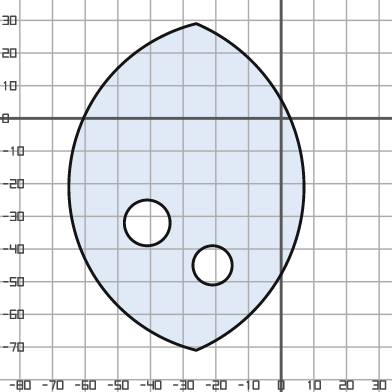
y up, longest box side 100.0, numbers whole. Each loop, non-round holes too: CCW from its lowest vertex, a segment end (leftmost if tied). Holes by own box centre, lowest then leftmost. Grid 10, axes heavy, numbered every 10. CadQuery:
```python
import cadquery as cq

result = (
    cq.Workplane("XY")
    .moveTo(-26.0, -71.0)
    .threePointArc((7.0, -21.0), (-26.0, 29.0))
    .threePointArc((-65.0, -21.0), (-26.0, -71.0))
    .close()
    .moveTo(-21.0, -45.0)
    .circle(6.0)
    .moveTo(-41.0, -32.0)
    .circle(7.0)
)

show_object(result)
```